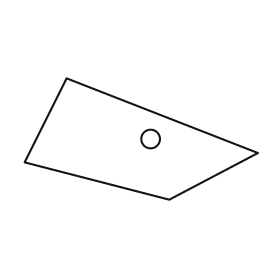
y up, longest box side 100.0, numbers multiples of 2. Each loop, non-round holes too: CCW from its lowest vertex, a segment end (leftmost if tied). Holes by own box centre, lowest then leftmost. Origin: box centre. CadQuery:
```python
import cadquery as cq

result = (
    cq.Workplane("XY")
    .moveTo(12.0, -26.0)
    .lineTo(50.0, -6.0)
    .lineTo(-32.0, 26.0)
    .lineTo(-50.0, -10.0)
    .close()
    .moveTo(4.0, 0.0)
    .circle(4.0)
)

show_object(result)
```